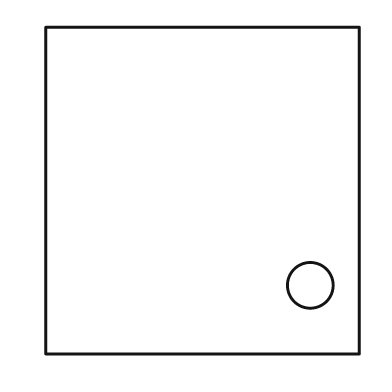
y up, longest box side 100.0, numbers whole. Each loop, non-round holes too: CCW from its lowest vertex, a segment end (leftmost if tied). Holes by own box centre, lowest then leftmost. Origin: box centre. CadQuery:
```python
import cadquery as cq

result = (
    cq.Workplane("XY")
    .moveTo(-48.0, -50.0)
    .lineTo(48.0, -50.0)
    .lineTo(48.0, 50.0)
    .lineTo(-48.0, 50.0)
    .close()
    .moveTo(33.0, -29.0)
    .circle(7.0)
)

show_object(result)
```